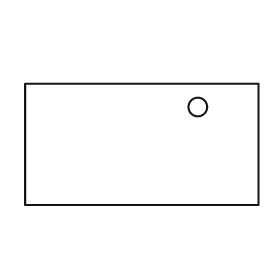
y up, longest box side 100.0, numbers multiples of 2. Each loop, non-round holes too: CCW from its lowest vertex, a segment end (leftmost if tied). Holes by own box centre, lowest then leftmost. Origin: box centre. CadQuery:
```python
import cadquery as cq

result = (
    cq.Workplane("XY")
    .moveTo(-50.0, -26.0)
    .lineTo(50.0, -26.0)
    .lineTo(50.0, 26.0)
    .lineTo(-50.0, 26.0)
    .close()
    .moveTo(24.0, 16.0)
    .circle(4.0)
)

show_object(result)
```